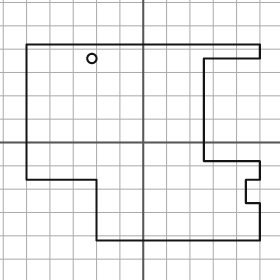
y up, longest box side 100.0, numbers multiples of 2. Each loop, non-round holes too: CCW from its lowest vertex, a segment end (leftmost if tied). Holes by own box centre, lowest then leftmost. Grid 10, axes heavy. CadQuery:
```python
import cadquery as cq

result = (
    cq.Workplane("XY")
    .moveTo(-20.0, -42.0)
    .lineTo(50.0, -42.0)
    .lineTo(50.0, -26.0)
    .lineTo(44.0, -26.0)
    .lineTo(44.0, -16.0)
    .lineTo(50.0, -16.0)
    .lineTo(50.0, -8.0)
    .lineTo(26.0, -8.0)
    .lineTo(26.0, 36.0)
    .lineTo(50.0, 36.0)
    .lineTo(50.0, 42.0)
    .lineTo(-50.0, 42.0)
    .lineTo(-50.0, -16.0)
    .lineTo(-20.0, -16.0)
    .close()
    .moveTo(-22.0, 36.0)
    .circle(2.0)
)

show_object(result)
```